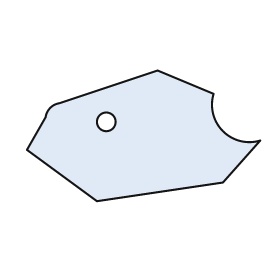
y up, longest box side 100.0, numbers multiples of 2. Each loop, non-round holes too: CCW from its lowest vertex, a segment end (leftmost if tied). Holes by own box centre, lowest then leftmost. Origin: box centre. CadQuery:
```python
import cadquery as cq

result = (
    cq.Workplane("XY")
    .moveTo(-20.0, -28.0)
    .lineTo(34.0, -20.0)
    .lineTo(50.0, -2.0)
    .threePointArc((34.0, 2.0), (30.0, 18.0))
    .lineTo(6.0, 28.0)
    .lineTo(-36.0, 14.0)
    .threePointArc((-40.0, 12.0), (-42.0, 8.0))
    .lineTo(-50.0, -6.0)
    .close()
    .moveTo(-16.0, 6.0)
    .circle(4.0)
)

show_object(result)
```